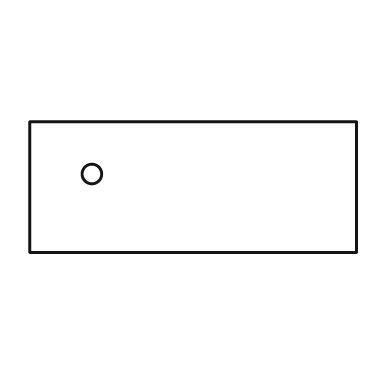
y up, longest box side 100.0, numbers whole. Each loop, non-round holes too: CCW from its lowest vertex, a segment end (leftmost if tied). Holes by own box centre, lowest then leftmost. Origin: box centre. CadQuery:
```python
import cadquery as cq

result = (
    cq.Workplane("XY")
    .moveTo(-50.0, -20.0)
    .lineTo(50.0, -20.0)
    .lineTo(50.0, 20.0)
    .lineTo(-50.0, 20.0)
    .close()
    .moveTo(-31.0, 4.0)
    .circle(3.0)
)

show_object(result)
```